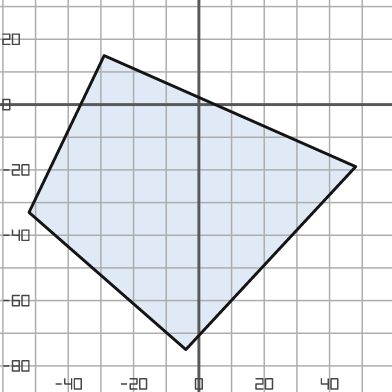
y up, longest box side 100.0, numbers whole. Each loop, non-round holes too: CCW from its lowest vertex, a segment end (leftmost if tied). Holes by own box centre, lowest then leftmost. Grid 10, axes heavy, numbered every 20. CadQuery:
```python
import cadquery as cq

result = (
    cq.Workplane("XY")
    .moveTo(-4.0, -75.0)
    .lineTo(48.0, -19.0)
    .lineTo(-29.0, 15.0)
    .lineTo(-52.0, -33.0)
    .close()
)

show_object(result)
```